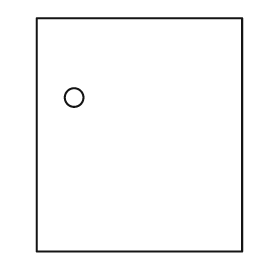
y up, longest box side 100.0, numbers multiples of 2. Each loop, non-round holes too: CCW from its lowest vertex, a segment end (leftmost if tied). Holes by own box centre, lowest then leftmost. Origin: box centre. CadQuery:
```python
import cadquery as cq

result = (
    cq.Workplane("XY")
    .moveTo(-44.0, -50.0)
    .lineTo(44.0, -50.0)
    .lineTo(44.0, 50.0)
    .lineTo(-44.0, 50.0)
    .close()
    .moveTo(-28.0, 16.0)
    .circle(4.0)
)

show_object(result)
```